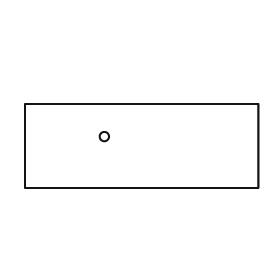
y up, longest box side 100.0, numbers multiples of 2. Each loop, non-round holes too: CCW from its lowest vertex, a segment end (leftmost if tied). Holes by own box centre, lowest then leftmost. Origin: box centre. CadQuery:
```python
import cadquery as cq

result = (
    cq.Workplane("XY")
    .moveTo(-50.0, -18.0)
    .lineTo(50.0, -18.0)
    .lineTo(50.0, 18.0)
    .lineTo(-50.0, 18.0)
    .close()
    .moveTo(-16.0, 4.0)
    .circle(2.0)
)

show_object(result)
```